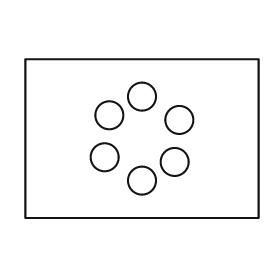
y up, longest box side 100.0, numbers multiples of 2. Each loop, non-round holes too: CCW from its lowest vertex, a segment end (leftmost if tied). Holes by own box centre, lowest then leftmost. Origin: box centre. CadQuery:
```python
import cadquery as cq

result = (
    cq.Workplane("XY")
    .moveTo(-50.0, -34.0)
    .lineTo(50.0, -34.0)
    .lineTo(50.0, 34.0)
    .lineTo(-50.0, 34.0)
    .close()
    .moveTo(0.0, -18.0)
    .circle(6.0)
    .moveTo(14.0, -10.0)
    .circle(6.0)
    .moveTo(-16.0, -8.0)
    .circle(6.0)
    .moveTo(16.0, 8.0)
    .circle(6.0)
    .moveTo(-14.0, 10.0)
    .circle(6.0)
    .moveTo(0.0, 18.0)
    .circle(6.0)
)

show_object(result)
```